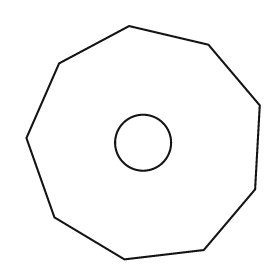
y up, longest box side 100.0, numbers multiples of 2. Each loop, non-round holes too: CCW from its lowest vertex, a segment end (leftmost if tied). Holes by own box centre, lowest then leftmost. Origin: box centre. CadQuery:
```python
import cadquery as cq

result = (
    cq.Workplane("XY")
    .moveTo(-8.0, -50.0)
    .lineTo(26.0, -46.0)
    .lineTo(48.0, -20.0)
    .lineTo(50.0, 16.0)
    .lineTo(28.0, 42.0)
    .lineTo(-6.0, 50.0)
    .lineTo(-36.0, 34.0)
    .lineTo(-50.0, 2.0)
    .lineTo(-38.0, -32.0)
    .close()
    .moveTo(0.0, 0.0)
    .circle(12.0)
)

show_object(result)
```